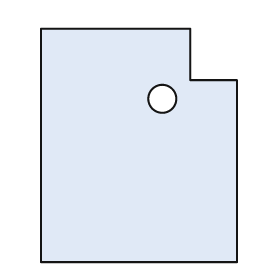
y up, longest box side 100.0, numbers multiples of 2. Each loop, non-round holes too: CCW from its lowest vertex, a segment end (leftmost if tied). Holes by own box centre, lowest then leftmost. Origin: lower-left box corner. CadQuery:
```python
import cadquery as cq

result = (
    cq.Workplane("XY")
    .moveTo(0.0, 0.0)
    .lineTo(84.0, 0.0)
    .lineTo(84.0, 78.0)
    .lineTo(64.0, 78.0)
    .lineTo(64.0, 100.0)
    .lineTo(0.0, 100.0)
    .close()
    .moveTo(52.0, 70.0)
    .circle(6.0)
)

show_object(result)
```